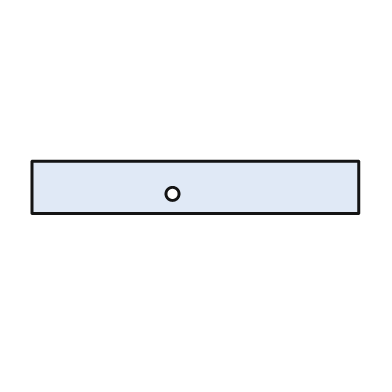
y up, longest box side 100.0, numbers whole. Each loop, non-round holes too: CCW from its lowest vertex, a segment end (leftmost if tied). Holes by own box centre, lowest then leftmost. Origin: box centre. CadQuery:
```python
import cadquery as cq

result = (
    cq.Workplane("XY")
    .moveTo(-50.0, -8.0)
    .lineTo(50.0, -8.0)
    .lineTo(50.0, 8.0)
    .lineTo(-50.0, 8.0)
    .close()
    .moveTo(-7.0, -2.0)
    .circle(2.0)
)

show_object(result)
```